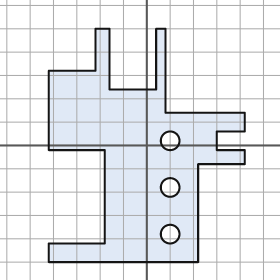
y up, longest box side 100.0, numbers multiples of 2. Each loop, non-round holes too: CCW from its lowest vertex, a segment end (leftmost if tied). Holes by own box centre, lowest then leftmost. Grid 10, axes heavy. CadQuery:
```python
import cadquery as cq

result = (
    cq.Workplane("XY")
    .moveTo(-42.0, -50.0)
    .lineTo(22.0, -50.0)
    .lineTo(22.0, -8.0)
    .lineTo(42.0, -8.0)
    .lineTo(42.0, -2.0)
    .lineTo(30.0, -2.0)
    .lineTo(30.0, 6.0)
    .lineTo(42.0, 6.0)
    .lineTo(42.0, 14.0)
    .lineTo(8.0, 14.0)
    .lineTo(8.0, 50.0)
    .lineTo(4.0, 50.0)
    .lineTo(4.0, 24.0)
    .lineTo(-16.0, 24.0)
    .lineTo(-16.0, 50.0)
    .lineTo(-22.0, 50.0)
    .lineTo(-22.0, 32.0)
    .lineTo(-42.0, 32.0)
    .lineTo(-42.0, -2.0)
    .lineTo(-18.0, -2.0)
    .lineTo(-18.0, -42.0)
    .lineTo(-42.0, -42.0)
    .close()
    .moveTo(10.0, -38.0)
    .circle(4.0)
    .moveTo(10.0, -18.0)
    .circle(4.0)
    .moveTo(10.0, 2.0)
    .circle(4.0)
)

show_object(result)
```